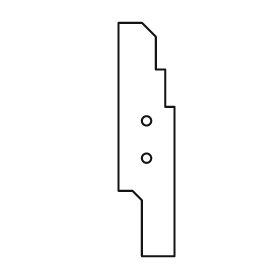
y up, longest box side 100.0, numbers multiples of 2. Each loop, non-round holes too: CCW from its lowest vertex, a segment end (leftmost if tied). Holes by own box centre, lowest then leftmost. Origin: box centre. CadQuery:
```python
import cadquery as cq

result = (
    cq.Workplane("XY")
    .moveTo(-2.0, -50.0)
    .lineTo(12.0, -50.0)
    .lineTo(12.0, 14.0)
    .lineTo(8.0, 14.0)
    .lineTo(8.0, 30.0)
    .lineTo(4.0, 30.0)
    .lineTo(4.0, 44.0)
    .lineTo(-2.0, 50.0)
    .lineTo(-12.0, 50.0)
    .lineTo(-12.0, -22.0)
    .lineTo(-6.0, -22.0)
    .lineTo(-2.0, -26.0)
    .close()
    .moveTo(0.0, -8.0)
    .circle(2.0)
    .moveTo(0.0, 8.0)
    .circle(2.0)
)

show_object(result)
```